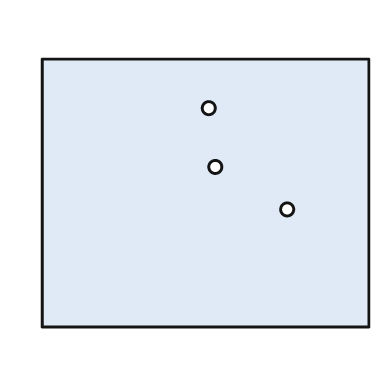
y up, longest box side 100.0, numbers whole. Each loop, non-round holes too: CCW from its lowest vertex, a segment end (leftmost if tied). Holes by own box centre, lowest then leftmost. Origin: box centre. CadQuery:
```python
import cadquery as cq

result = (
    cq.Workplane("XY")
    .moveTo(-50.0, -41.0)
    .lineTo(50.0, -41.0)
    .lineTo(50.0, 41.0)
    .lineTo(-50.0, 41.0)
    .close()
    .moveTo(25.0, -5.0)
    .circle(2.0)
    .moveTo(3.0, 8.0)
    .circle(2.0)
    .moveTo(1.0, 26.0)
    .circle(2.0)
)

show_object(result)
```